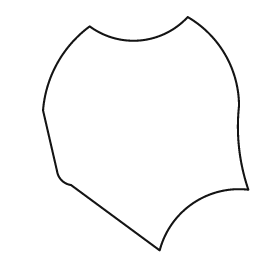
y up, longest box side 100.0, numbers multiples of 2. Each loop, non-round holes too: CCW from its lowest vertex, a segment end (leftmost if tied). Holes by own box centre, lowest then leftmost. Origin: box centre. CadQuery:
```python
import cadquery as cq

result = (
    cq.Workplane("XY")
    .moveTo(6.0, -50.0)
    .threePointArc((20.0, -30.0), (44.0, -24.0))
    .threePointArc((40.0, -6.0), (40.0, 12.0))
    .threePointArc((34.0, 34.0), (18.0, 50.0))
    .threePointArc((-2.0, 40.0), (-24.0, 46.0))
    .threePointArc((-38.0, 30.0), (-44.0, 10.0))
    .lineTo(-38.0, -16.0)
    .threePointArc((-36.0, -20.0), (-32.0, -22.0))
    .close()
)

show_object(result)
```